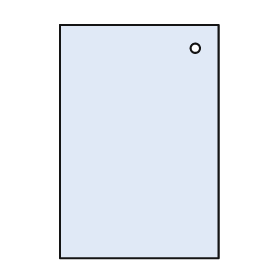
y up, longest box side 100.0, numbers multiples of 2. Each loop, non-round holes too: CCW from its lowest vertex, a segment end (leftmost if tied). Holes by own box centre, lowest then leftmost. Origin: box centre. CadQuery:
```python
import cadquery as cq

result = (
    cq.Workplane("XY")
    .moveTo(-34.0, -50.0)
    .lineTo(34.0, -50.0)
    .lineTo(34.0, 50.0)
    .lineTo(-34.0, 50.0)
    .close()
    .moveTo(24.0, 40.0)
    .circle(2.0)
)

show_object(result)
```